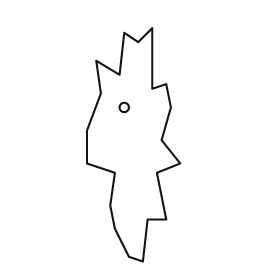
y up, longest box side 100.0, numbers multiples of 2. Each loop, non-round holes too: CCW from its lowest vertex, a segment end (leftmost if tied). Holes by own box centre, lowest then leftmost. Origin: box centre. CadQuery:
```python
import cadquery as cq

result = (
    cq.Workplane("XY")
    .moveTo(4.0, -50.0)
    .lineTo(6.0, -32.0)
    .lineTo(14.0, -32.0)
    .lineTo(10.0, -12.0)
    .lineTo(20.0, -8.0)
    .lineTo(12.0, 2.0)
    .lineTo(16.0, 16.0)
    .lineTo(14.0, 26.0)
    .lineTo(8.0, 24.0)
    .lineTo(8.0, 50.0)
    .lineTo(2.0, 44.0)
    .lineTo(-4.0, 48.0)
    .lineTo(-6.0, 30.0)
    .lineTo(-16.0, 36.0)
    .lineTo(-14.0, 22.0)
    .lineTo(-20.0, 6.0)
    .lineTo(-20.0, -8.0)
    .lineTo(-8.0, -12.0)
    .lineTo(-10.0, -26.0)
    .lineTo(-8.0, -36.0)
    .lineTo(-2.0, -48.0)
    .close()
    .moveTo(-4.0, 16.0)
    .circle(2.0)
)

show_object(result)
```